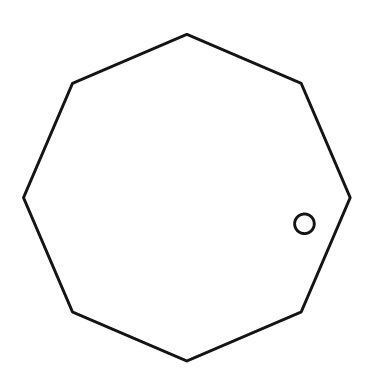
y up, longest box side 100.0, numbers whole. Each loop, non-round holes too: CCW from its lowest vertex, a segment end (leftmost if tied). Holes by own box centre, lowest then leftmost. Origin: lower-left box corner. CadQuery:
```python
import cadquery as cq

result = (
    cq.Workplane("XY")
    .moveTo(50.0, 0.0)
    .lineTo(85.0, 15.0)
    .lineTo(100.0, 50.0)
    .lineTo(85.0, 85.0)
    .lineTo(50.0, 100.0)
    .lineTo(15.0, 85.0)
    .lineTo(0.0, 50.0)
    .lineTo(15.0, 15.0)
    .close()
    .moveTo(86.0, 42.0)
    .circle(3.0)
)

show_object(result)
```